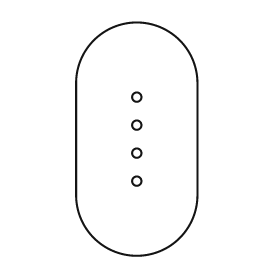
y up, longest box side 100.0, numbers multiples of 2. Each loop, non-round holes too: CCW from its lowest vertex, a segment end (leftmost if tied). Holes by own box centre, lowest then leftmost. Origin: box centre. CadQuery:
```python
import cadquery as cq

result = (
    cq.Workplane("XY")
    .moveTo(-26.0, -24.0)
    .threePointArc((0.0, -50.0), (26.0, -24.0))
    .lineTo(26.0, 24.0)
    .threePointArc((0.0, 50.0), (-26.0, 24.0))
    .close()
    .moveTo(0.0, -18.0)
    .circle(2.0)
    .moveTo(0.0, -6.0)
    .circle(2.0)
    .moveTo(0.0, 6.0)
    .circle(2.0)
    .moveTo(0.0, 18.0)
    .circle(2.0)
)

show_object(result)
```